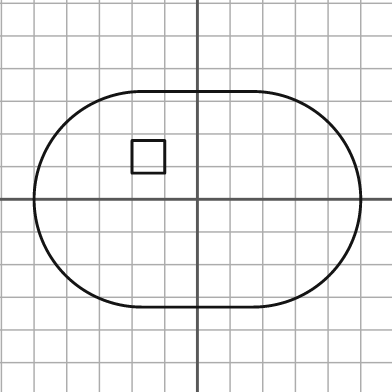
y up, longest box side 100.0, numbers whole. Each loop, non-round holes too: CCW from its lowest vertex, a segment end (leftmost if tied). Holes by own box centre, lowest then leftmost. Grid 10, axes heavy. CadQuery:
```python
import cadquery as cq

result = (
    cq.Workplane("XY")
    .moveTo(-17.0, -33.0)
    .lineTo(17.0, -33.0)
    .threePointArc((50.0, 0.0), (17.0, 33.0))
    .lineTo(-17.0, 33.0)
    .threePointArc((-50.0, 0.0), (-17.0, -33.0))
    .close()
    .moveTo(-20.0, 8.0)
    .lineTo(-10.0, 8.0)
    .lineTo(-10.0, 18.0)
    .lineTo(-20.0, 18.0)
    .close()
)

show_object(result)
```